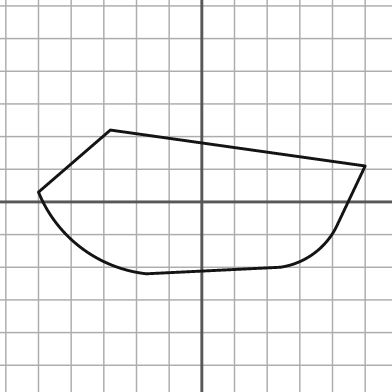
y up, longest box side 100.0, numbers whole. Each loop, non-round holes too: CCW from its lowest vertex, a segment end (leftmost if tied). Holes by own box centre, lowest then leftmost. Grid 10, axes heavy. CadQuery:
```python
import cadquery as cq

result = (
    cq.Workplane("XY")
    .moveTo(-17.0, -22.0)
    .lineTo(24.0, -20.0)
    .threePointArc((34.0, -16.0), (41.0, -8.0))
    .lineTo(50.0, 11.0)
    .lineTo(-28.0, 22.0)
    .lineTo(-50.0, 3.0)
    .threePointArc((-37.0, -14.0), (-17.0, -22.0))
    .close()
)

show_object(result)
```